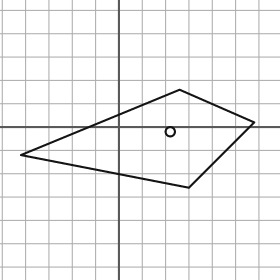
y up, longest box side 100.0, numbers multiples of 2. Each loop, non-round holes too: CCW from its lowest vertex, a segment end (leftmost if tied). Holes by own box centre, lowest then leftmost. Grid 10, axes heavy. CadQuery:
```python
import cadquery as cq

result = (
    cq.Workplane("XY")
    .moveTo(30.0, -26.0)
    .lineTo(58.0, 2.0)
    .lineTo(26.0, 16.0)
    .lineTo(-42.0, -12.0)
    .close()
    .moveTo(22.0, -2.0)
    .circle(2.0)
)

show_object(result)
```